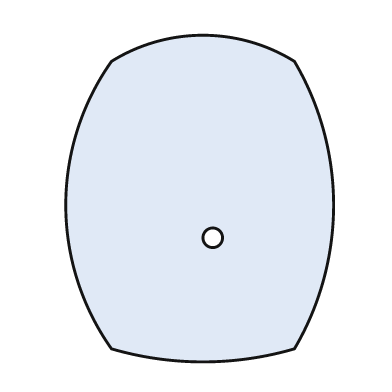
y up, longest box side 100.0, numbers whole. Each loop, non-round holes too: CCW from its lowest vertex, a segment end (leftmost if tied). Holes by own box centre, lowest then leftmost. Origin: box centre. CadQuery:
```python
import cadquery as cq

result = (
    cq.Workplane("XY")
    .moveTo(-27.0, -46.0)
    .threePointArc((1.0, -50.0), (29.0, -46.0))
    .threePointArc((41.0, -2.0), (29.0, 42.0))
    .threePointArc((1.0, 50.0), (-27.0, 42.0))
    .threePointArc((-41.0, -2.0), (-27.0, -46.0))
    .close()
    .moveTo(4.0, -12.0)
    .circle(3.0)
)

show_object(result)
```